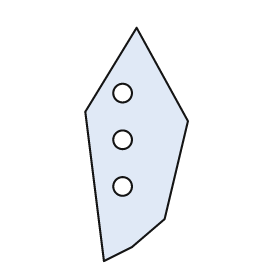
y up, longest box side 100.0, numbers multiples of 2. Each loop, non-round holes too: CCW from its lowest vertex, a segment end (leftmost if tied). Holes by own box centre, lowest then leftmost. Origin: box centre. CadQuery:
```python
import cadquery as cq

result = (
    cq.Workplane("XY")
    .moveTo(-14.0, -50.0)
    .lineTo(-2.0, -44.0)
    .lineTo(12.0, -32.0)
    .lineTo(22.0, 10.0)
    .lineTo(0.0, 50.0)
    .lineTo(-22.0, 14.0)
    .close()
    .moveTo(-6.0, -18.0)
    .circle(4.0)
    .moveTo(-6.0, 2.0)
    .circle(4.0)
    .moveTo(-6.0, 22.0)
    .circle(4.0)
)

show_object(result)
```